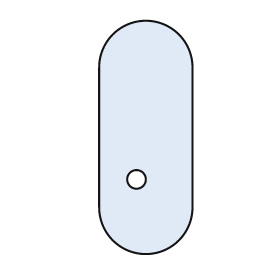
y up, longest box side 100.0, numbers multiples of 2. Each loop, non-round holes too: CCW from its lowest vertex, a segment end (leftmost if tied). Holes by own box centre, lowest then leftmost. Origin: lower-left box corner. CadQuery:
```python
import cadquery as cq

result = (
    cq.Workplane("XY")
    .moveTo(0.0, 20.0)
    .threePointArc((20.0, 0.0), (40.0, 20.0))
    .lineTo(40.0, 80.0)
    .threePointArc((20.0, 100.0), (0.0, 80.0))
    .close()
    .moveTo(16.0, 32.0)
    .circle(4.0)
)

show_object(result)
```